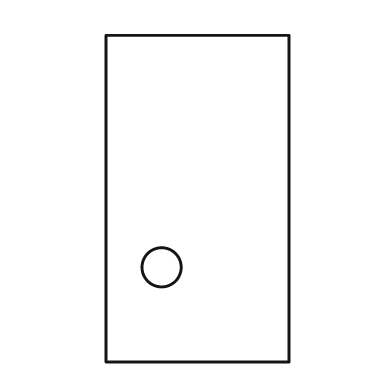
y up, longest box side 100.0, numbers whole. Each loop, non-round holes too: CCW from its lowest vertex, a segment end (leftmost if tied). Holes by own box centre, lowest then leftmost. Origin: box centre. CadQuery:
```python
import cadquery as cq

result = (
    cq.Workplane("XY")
    .moveTo(-28.0, -50.0)
    .lineTo(28.0, -50.0)
    .lineTo(28.0, 50.0)
    .lineTo(-28.0, 50.0)
    .close()
    .moveTo(-11.0, -21.0)
    .circle(6.0)
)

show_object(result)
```